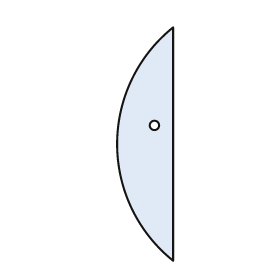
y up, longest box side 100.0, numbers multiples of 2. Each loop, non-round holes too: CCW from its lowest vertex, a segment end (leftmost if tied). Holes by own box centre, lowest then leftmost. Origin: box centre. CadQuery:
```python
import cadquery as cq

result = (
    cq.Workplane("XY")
    .moveTo(12.0, -50.0)
    .lineTo(12.0, 50.0)
    .threePointArc((-12.0, 0.0), (12.0, -50.0))
    .close()
    .moveTo(4.0, 8.0)
    .circle(2.0)
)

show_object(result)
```